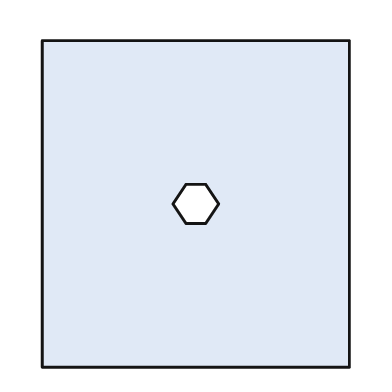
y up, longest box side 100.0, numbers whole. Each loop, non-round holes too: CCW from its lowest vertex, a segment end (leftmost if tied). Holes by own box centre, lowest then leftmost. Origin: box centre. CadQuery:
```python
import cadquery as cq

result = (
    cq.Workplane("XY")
    .moveTo(-47.0, -50.0)
    .lineTo(47.0, -50.0)
    .lineTo(47.0, 50.0)
    .lineTo(-47.0, 50.0)
    .close()
    .moveTo(-3.0, -6.0)
    .lineTo(3.0, -6.0)
    .lineTo(7.0, 0.0)
    .lineTo(3.0, 6.0)
    .lineTo(-3.0, 6.0)
    .lineTo(-7.0, 0.0)
    .close()
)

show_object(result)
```